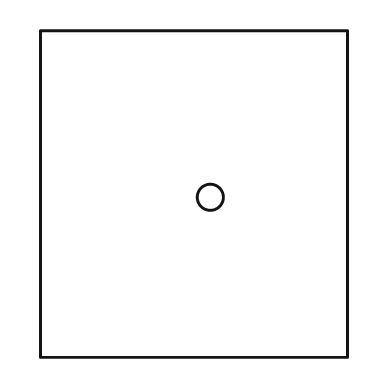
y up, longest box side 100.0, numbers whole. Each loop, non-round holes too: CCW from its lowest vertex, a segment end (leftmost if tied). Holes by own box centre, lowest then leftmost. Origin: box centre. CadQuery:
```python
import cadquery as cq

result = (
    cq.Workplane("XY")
    .moveTo(-47.0, -50.0)
    .lineTo(47.0, -50.0)
    .lineTo(47.0, 50.0)
    .lineTo(-47.0, 50.0)
    .close()
    .moveTo(5.0, -1.0)
    .circle(4.0)
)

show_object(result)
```